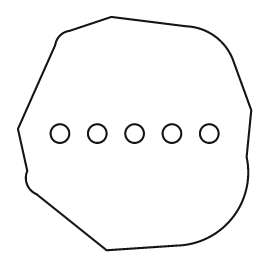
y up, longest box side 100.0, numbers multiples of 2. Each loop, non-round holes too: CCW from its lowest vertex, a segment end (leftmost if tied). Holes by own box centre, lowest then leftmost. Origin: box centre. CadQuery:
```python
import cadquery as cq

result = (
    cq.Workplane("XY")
    .moveTo(-12.0, -50.0)
    .lineTo(18.0, -48.0)
    .threePointArc((42.0, -36.0), (48.0, -10.0))
    .lineTo(50.0, 10.0)
    .lineTo(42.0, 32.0)
    .threePointArc((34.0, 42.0), (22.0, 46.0))
    .lineTo(-10.0, 50.0)
    .lineTo(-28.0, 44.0)
    .threePointArc((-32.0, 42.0), (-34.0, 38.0))
    .lineTo(-50.0, 2.0)
    .lineTo(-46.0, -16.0)
    .threePointArc((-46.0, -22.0), (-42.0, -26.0))
    .close()
    .moveTo(-32.0, 0.0)
    .circle(4.0)
    .moveTo(-16.0, 0.0)
    .circle(4.0)
    .moveTo(0.0, 0.0)
    .circle(4.0)
    .moveTo(16.0, 0.0)
    .circle(4.0)
    .moveTo(32.0, 0.0)
    .circle(4.0)
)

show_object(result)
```